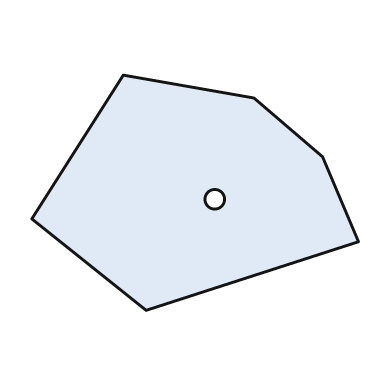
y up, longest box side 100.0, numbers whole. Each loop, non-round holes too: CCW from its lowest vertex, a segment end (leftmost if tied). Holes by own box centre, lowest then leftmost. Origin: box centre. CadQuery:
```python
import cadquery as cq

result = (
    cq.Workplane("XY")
    .moveTo(-15.0, -36.0)
    .lineTo(50.0, -15.0)
    .lineTo(39.0, 11.0)
    .lineTo(18.0, 29.0)
    .lineTo(-22.0, 36.0)
    .lineTo(-50.0, -8.0)
    .close()
    .moveTo(6.0, -2.0)
    .circle(3.0)
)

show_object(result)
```